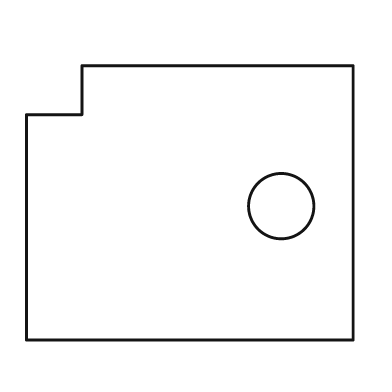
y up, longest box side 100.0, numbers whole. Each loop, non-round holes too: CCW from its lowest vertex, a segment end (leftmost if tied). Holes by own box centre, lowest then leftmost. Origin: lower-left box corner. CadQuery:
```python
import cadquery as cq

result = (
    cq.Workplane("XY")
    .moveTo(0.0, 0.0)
    .lineTo(100.0, 0.0)
    .lineTo(100.0, 84.0)
    .lineTo(17.0, 84.0)
    .lineTo(17.0, 69.0)
    .lineTo(0.0, 69.0)
    .close()
    .moveTo(78.0, 41.0)
    .circle(10.0)
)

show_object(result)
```